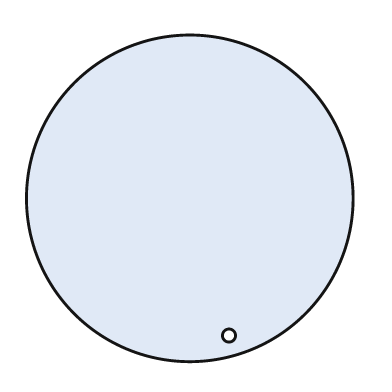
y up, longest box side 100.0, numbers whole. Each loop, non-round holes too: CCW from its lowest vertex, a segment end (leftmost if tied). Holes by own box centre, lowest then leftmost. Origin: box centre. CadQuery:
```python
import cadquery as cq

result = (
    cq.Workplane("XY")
    .moveTo(0.0, 0.0)
    .circle(50.0)
    .moveTo(12.0, -42.0)
    .circle(2.0)
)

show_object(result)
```